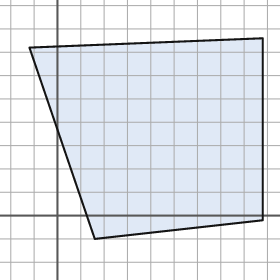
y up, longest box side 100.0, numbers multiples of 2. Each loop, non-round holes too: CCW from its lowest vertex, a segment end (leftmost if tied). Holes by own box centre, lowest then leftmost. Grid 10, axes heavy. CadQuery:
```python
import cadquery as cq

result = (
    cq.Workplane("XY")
    .moveTo(16.0, -10.0)
    .lineTo(88.0, -2.0)
    .lineTo(88.0, 76.0)
    .lineTo(-12.0, 72.0)
    .close()
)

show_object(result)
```